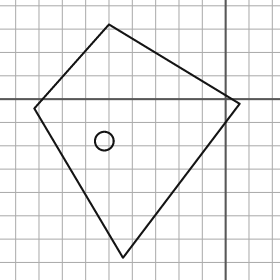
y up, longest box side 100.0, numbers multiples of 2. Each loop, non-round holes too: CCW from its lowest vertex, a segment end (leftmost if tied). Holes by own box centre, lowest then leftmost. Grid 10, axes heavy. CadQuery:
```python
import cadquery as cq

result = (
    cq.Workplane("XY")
    .moveTo(-44.0, -68.0)
    .lineTo(6.0, -2.0)
    .lineTo(-50.0, 32.0)
    .lineTo(-82.0, -4.0)
    .close()
    .moveTo(-52.0, -18.0)
    .circle(4.0)
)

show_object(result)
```